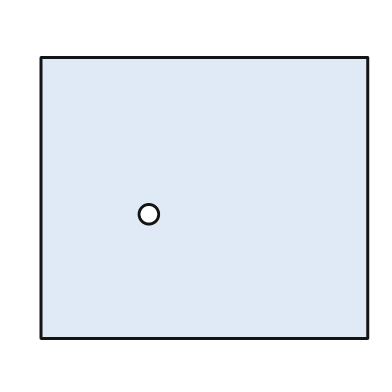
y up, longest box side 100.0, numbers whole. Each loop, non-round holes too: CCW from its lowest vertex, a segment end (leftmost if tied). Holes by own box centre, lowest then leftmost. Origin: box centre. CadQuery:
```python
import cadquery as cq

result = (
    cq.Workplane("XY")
    .moveTo(-50.0, -43.0)
    .lineTo(50.0, -43.0)
    .lineTo(50.0, 43.0)
    .lineTo(-50.0, 43.0)
    .close()
    .moveTo(-17.0, -5.0)
    .circle(3.0)
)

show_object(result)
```